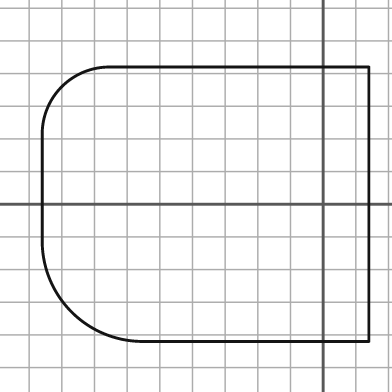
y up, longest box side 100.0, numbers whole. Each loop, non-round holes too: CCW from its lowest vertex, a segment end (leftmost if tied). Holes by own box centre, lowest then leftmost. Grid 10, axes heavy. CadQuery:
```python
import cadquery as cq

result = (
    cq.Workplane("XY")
    .moveTo(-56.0, -42.0)
    .lineTo(14.0, -42.0)
    .lineTo(14.0, 42.0)
    .lineTo(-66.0, 42.0)
    .threePointArc((-80.0, 36.0), (-86.0, 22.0))
    .lineTo(-86.0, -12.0)
    .threePointArc((-77.0, -33.0), (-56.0, -42.0))
    .close()
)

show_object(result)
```